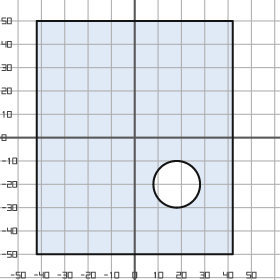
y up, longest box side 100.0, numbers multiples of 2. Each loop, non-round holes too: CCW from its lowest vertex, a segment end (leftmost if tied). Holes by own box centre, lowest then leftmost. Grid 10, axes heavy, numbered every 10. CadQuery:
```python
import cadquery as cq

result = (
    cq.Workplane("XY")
    .moveTo(-42.0, -50.0)
    .lineTo(42.0, -50.0)
    .lineTo(42.0, 50.0)
    .lineTo(-42.0, 50.0)
    .close()
    .moveTo(18.0, -20.0)
    .circle(10.0)
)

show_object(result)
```